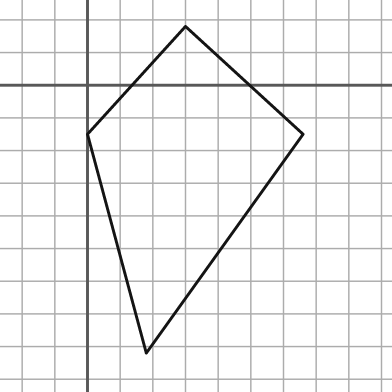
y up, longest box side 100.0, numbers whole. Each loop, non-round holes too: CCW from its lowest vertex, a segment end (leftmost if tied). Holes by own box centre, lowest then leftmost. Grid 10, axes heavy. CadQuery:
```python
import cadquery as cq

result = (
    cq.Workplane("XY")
    .moveTo(18.0, -82.0)
    .lineTo(66.0, -15.0)
    .lineTo(30.0, 18.0)
    .lineTo(0.0, -15.0)
    .close()
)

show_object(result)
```